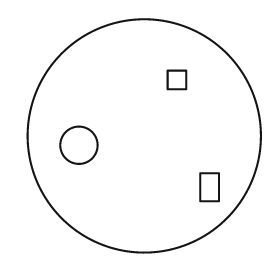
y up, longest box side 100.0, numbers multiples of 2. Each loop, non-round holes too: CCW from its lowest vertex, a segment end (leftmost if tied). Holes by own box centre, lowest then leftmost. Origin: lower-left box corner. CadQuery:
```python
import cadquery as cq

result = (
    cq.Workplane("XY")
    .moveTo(50.0, 50.0)
    .circle(50.0)
    .moveTo(74.0, 22.0)
    .lineTo(82.0, 22.0)
    .lineTo(82.0, 34.0)
    .lineTo(74.0, 34.0)
    .close()
    .moveTo(22.0, 46.0)
    .circle(8.0)
    .moveTo(60.0, 70.0)
    .lineTo(68.0, 70.0)
    .lineTo(68.0, 78.0)
    .lineTo(60.0, 78.0)
    .close()
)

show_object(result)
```